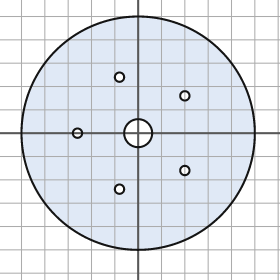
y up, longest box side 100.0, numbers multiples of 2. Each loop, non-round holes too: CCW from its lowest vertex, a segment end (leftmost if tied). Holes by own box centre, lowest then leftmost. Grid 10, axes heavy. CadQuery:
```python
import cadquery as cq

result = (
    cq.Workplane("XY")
    .moveTo(0.0, 0.0)
    .circle(50.0)
    .moveTo(-8.0, -24.0)
    .circle(2.0)
    .moveTo(20.0, -16.0)
    .circle(2.0)
    .moveTo(-26.0, 0.0)
    .circle(2.0)
    .moveTo(0.0, 0.0)
    .circle(6.0)
    .moveTo(20.0, 16.0)
    .circle(2.0)
    .moveTo(-8.0, 24.0)
    .circle(2.0)
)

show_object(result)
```